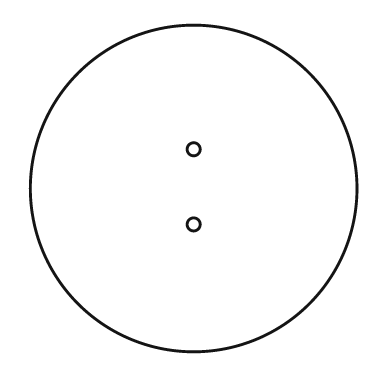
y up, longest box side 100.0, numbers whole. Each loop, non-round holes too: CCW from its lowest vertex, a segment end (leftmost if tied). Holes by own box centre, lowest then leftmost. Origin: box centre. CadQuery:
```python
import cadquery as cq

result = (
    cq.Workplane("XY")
    .moveTo(0.0, 0.0)
    .circle(50.0)
    .moveTo(0.0, -11.0)
    .circle(2.0)
    .moveTo(0.0, 12.0)
    .circle(2.0)
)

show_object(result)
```